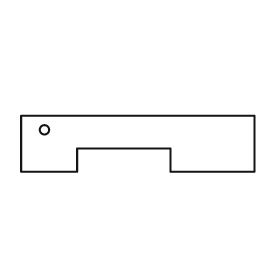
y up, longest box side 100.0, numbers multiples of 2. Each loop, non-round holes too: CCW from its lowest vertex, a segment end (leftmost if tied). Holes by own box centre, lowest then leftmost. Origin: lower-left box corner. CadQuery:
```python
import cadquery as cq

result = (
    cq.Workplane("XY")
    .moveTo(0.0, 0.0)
    .lineTo(24.0, 0.0)
    .lineTo(24.0, 10.0)
    .lineTo(64.0, 10.0)
    .lineTo(64.0, 0.0)
    .lineTo(100.0, 0.0)
    .lineTo(100.0, 24.0)
    .lineTo(0.0, 24.0)
    .close()
    .moveTo(10.0, 18.0)
    .circle(2.0)
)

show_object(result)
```